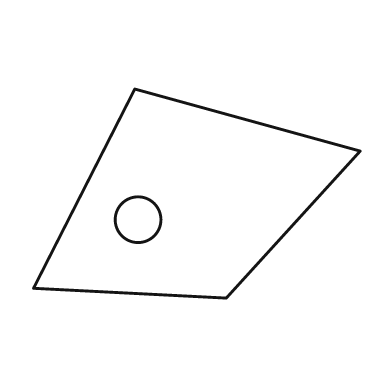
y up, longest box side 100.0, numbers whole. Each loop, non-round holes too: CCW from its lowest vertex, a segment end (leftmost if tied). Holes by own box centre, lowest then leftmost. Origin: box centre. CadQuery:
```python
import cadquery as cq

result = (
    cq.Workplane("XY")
    .moveTo(9.0, -32.0)
    .lineTo(50.0, 13.0)
    .lineTo(-19.0, 32.0)
    .lineTo(-50.0, -29.0)
    .close()
    .moveTo(-18.0, -8.0)
    .circle(7.0)
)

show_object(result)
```